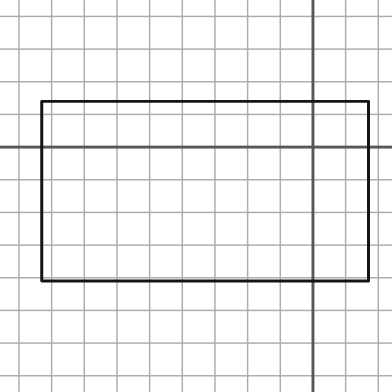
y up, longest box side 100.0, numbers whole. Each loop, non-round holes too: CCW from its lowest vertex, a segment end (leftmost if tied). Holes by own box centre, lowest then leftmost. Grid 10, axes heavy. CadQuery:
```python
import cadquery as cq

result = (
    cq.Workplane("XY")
    .moveTo(-83.0, -41.0)
    .lineTo(17.0, -41.0)
    .lineTo(17.0, 14.0)
    .lineTo(-83.0, 14.0)
    .close()
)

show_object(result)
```